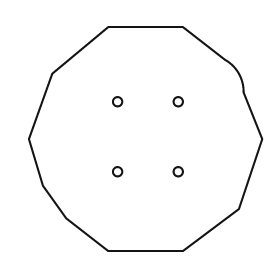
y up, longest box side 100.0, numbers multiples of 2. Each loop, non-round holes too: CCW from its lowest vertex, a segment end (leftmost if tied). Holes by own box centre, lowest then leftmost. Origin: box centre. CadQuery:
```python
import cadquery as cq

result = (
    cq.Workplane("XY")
    .moveTo(-16.0, -48.0)
    .lineTo(16.0, -48.0)
    .lineTo(40.0, -30.0)
    .lineTo(50.0, 0.0)
    .lineTo(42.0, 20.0)
    .threePointArc((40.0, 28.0), (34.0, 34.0))
    .lineTo(16.0, 48.0)
    .lineTo(-16.0, 48.0)
    .lineTo(-40.0, 28.0)
    .lineTo(-50.0, 0.0)
    .lineTo(-44.0, -20.0)
    .lineTo(-34.0, -34.0)
    .close()
    .moveTo(-12.0, -14.0)
    .circle(2.0)
    .moveTo(14.0, -14.0)
    .circle(2.0)
    .moveTo(-12.0, 16.0)
    .circle(2.0)
    .moveTo(14.0, 16.0)
    .circle(2.0)
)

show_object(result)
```